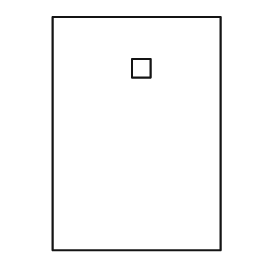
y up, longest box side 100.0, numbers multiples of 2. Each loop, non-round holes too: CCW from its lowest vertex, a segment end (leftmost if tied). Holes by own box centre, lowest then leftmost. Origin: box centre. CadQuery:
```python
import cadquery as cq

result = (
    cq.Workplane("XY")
    .moveTo(-36.0, -50.0)
    .lineTo(36.0, -50.0)
    .lineTo(36.0, 50.0)
    .lineTo(-36.0, 50.0)
    .close()
    .moveTo(-2.0, 24.0)
    .lineTo(6.0, 24.0)
    .lineTo(6.0, 32.0)
    .lineTo(-2.0, 32.0)
    .close()
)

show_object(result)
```